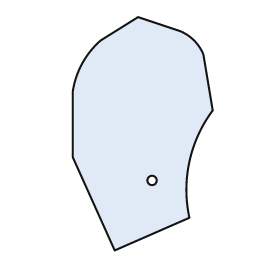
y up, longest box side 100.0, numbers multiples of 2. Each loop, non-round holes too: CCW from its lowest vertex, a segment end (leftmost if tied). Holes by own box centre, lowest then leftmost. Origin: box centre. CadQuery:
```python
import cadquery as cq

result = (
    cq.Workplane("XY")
    .moveTo(-12.0, -50.0)
    .lineTo(20.0, -36.0)
    .threePointArc((20.0, -12.0), (30.0, 10.0))
    .lineTo(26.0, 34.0)
    .threePointArc((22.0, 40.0), (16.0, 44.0))
    .lineTo(-2.0, 50.0)
    .lineTo(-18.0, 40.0)
    .threePointArc((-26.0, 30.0), (-30.0, 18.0))
    .lineTo(-30.0, -10.0)
    .close()
    .moveTo(4.0, -20.0)
    .circle(2.0)
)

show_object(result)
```